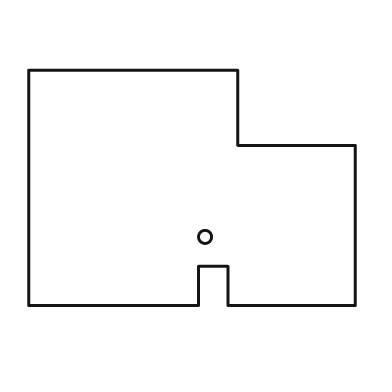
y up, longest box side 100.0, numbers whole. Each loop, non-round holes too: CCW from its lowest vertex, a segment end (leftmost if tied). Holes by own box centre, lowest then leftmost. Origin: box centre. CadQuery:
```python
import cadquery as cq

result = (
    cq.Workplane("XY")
    .moveTo(-50.0, -36.0)
    .lineTo(2.0, -36.0)
    .lineTo(2.0, -24.0)
    .lineTo(11.0, -24.0)
    .lineTo(11.0, -36.0)
    .lineTo(50.0, -36.0)
    .lineTo(50.0, 13.0)
    .lineTo(14.0, 13.0)
    .lineTo(14.0, 36.0)
    .lineTo(-50.0, 36.0)
    .close()
    .moveTo(4.0, -15.0)
    .circle(2.0)
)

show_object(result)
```